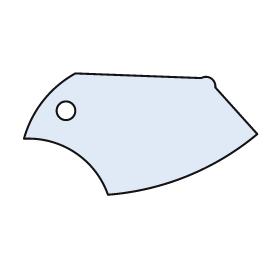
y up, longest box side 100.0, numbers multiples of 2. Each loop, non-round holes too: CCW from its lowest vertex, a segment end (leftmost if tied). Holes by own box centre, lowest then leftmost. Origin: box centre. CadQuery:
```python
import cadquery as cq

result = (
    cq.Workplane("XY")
    .moveTo(-14.0, -26.0)
    .threePointArc((20.0, -18.0), (50.0, 0.0))
    .lineTo(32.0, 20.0)
    .threePointArc((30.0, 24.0), (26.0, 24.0))
    .lineTo(-28.0, 26.0)
    .threePointArc((-42.0, 14.0), (-50.0, -2.0))
    .threePointArc((-28.0, -8.0), (-14.0, -26.0))
    .close()
    .moveTo(-32.0, 10.0)
    .circle(4.0)
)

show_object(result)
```